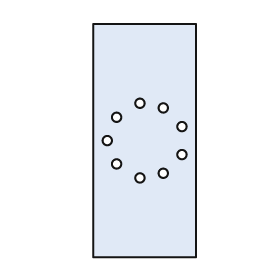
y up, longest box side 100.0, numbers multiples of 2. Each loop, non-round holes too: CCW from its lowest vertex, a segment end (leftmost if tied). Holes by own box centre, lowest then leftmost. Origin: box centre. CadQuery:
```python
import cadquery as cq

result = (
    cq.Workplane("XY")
    .moveTo(-22.0, -50.0)
    .lineTo(22.0, -50.0)
    .lineTo(22.0, 50.0)
    .lineTo(-22.0, 50.0)
    .close()
    .moveTo(-2.0, -16.0)
    .circle(2.0)
    .moveTo(8.0, -14.0)
    .circle(2.0)
    .moveTo(-12.0, -10.0)
    .circle(2.0)
    .moveTo(16.0, -6.0)
    .circle(2.0)
    .moveTo(-16.0, 0.0)
    .circle(2.0)
    .moveTo(16.0, 6.0)
    .circle(2.0)
    .moveTo(-12.0, 10.0)
    .circle(2.0)
    .moveTo(8.0, 14.0)
    .circle(2.0)
    .moveTo(-2.0, 16.0)
    .circle(2.0)
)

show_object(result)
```